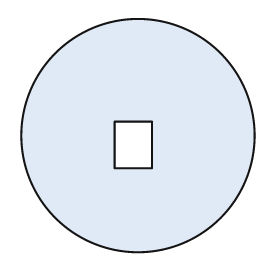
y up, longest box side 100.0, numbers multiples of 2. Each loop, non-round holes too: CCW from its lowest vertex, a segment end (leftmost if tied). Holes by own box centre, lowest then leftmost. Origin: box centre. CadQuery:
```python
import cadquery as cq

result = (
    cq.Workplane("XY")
    .moveTo(0.0, 0.0)
    .circle(50.0)
    .moveTo(-10.0, -14.0)
    .lineTo(6.0, -14.0)
    .lineTo(6.0, 6.0)
    .lineTo(-10.0, 6.0)
    .close()
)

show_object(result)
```